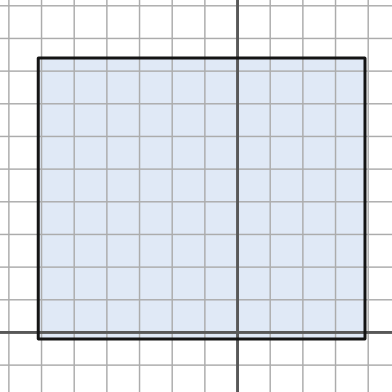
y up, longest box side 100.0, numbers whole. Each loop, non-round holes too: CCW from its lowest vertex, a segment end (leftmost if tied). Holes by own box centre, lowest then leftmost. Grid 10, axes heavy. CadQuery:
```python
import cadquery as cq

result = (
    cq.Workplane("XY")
    .moveTo(-61.0, -2.0)
    .lineTo(39.0, -2.0)
    .lineTo(39.0, 84.0)
    .lineTo(-61.0, 84.0)
    .close()
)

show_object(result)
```